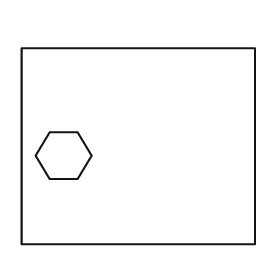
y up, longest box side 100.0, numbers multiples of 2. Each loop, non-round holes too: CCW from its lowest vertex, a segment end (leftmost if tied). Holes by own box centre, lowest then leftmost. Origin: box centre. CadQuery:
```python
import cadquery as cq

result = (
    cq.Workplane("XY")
    .moveTo(-50.0, -42.0)
    .lineTo(50.0, -42.0)
    .lineTo(50.0, 42.0)
    .lineTo(-50.0, 42.0)
    .close()
    .moveTo(-38.0, -14.0)
    .lineTo(-26.0, -14.0)
    .lineTo(-20.0, -4.0)
    .lineTo(-26.0, 6.0)
    .lineTo(-38.0, 6.0)
    .lineTo(-44.0, -4.0)
    .close()
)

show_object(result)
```